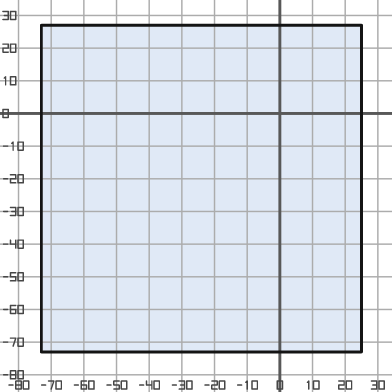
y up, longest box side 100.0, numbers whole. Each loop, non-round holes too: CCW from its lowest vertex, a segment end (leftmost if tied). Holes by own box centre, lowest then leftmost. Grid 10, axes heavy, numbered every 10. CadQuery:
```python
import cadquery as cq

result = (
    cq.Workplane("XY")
    .moveTo(-73.0, -73.0)
    .lineTo(25.0, -73.0)
    .lineTo(25.0, 27.0)
    .lineTo(-73.0, 27.0)
    .close()
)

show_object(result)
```